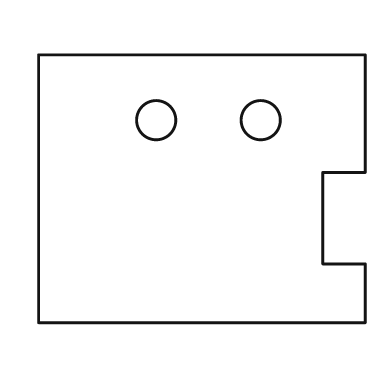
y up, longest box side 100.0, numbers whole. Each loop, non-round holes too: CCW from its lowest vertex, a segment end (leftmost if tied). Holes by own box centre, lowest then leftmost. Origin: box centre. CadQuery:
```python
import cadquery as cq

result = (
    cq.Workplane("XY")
    .moveTo(-50.0, -41.0)
    .lineTo(50.0, -41.0)
    .lineTo(50.0, -23.0)
    .lineTo(37.0, -23.0)
    .lineTo(37.0, 5.0)
    .lineTo(50.0, 5.0)
    .lineTo(50.0, 41.0)
    .lineTo(-50.0, 41.0)
    .close()
    .moveTo(-14.0, 21.0)
    .circle(6.0)
    .moveTo(18.0, 21.0)
    .circle(6.0)
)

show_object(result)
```